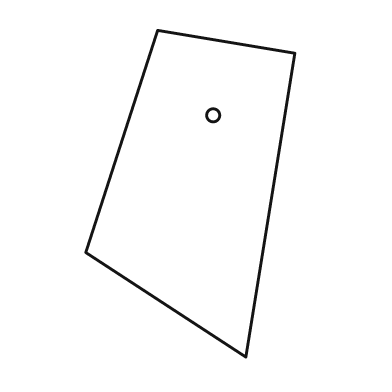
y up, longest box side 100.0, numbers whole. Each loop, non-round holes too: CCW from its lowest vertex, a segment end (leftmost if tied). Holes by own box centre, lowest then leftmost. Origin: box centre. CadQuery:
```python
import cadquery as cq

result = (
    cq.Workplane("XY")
    .moveTo(17.0, -50.0)
    .lineTo(32.0, 43.0)
    .lineTo(-10.0, 50.0)
    .lineTo(-32.0, -18.0)
    .close()
    .moveTo(7.0, 24.0)
    .circle(2.0)
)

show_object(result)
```